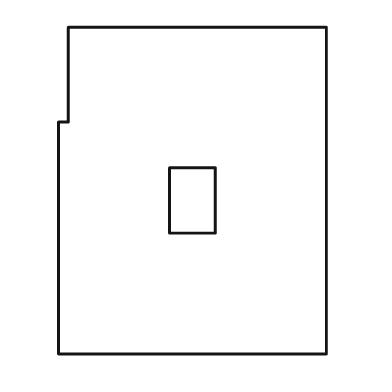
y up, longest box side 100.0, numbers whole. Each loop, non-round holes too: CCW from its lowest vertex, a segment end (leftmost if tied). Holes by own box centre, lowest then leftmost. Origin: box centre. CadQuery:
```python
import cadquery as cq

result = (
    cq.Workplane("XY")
    .moveTo(-41.0, -50.0)
    .lineTo(41.0, -50.0)
    .lineTo(41.0, 50.0)
    .lineTo(-38.0, 50.0)
    .lineTo(-38.0, 21.0)
    .lineTo(-41.0, 21.0)
    .close()
    .moveTo(-7.0, -13.0)
    .lineTo(7.0, -13.0)
    .lineTo(7.0, 7.0)
    .lineTo(-7.0, 7.0)
    .close()
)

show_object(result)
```